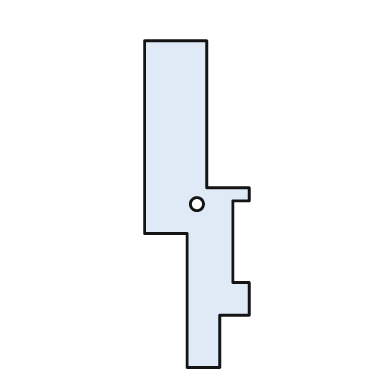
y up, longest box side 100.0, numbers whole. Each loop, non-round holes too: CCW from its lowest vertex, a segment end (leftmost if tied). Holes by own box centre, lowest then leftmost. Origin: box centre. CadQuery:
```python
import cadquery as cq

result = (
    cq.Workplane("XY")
    .moveTo(-3.0, -50.0)
    .lineTo(7.0, -50.0)
    .lineTo(7.0, -34.0)
    .lineTo(16.0, -34.0)
    .lineTo(16.0, -24.0)
    .lineTo(11.0, -24.0)
    .lineTo(11.0, 1.0)
    .lineTo(16.0, 1.0)
    .lineTo(16.0, 5.0)
    .lineTo(3.0, 5.0)
    .lineTo(3.0, 50.0)
    .lineTo(-16.0, 50.0)
    .lineTo(-16.0, -9.0)
    .lineTo(-3.0, -9.0)
    .close()
    .moveTo(0.0, 0.0)
    .circle(2.0)
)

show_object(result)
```